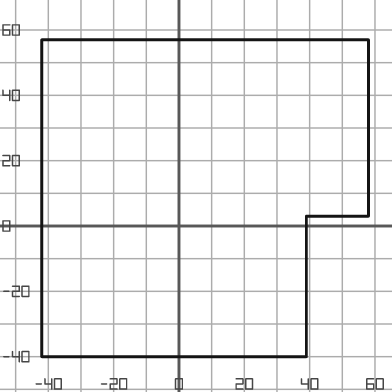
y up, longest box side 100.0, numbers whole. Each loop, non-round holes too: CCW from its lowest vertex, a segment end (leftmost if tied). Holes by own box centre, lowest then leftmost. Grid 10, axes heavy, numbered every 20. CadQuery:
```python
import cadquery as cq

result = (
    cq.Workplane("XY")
    .moveTo(-42.0, -40.0)
    .lineTo(39.0, -40.0)
    .lineTo(39.0, 3.0)
    .lineTo(58.0, 3.0)
    .lineTo(58.0, 57.0)
    .lineTo(-42.0, 57.0)
    .close()
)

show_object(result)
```